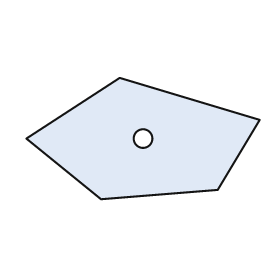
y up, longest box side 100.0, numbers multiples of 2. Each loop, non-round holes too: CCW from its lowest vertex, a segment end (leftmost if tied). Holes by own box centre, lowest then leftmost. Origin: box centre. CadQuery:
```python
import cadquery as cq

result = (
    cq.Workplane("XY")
    .moveTo(-18.0, -26.0)
    .lineTo(32.0, -22.0)
    .lineTo(50.0, 8.0)
    .lineTo(-10.0, 26.0)
    .lineTo(-50.0, 0.0)
    .close()
    .moveTo(0.0, 0.0)
    .circle(4.0)
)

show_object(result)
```